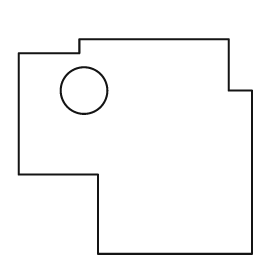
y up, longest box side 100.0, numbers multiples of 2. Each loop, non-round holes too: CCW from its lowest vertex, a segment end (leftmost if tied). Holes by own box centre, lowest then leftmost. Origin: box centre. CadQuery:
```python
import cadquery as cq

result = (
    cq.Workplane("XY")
    .moveTo(-16.0, -46.0)
    .lineTo(50.0, -46.0)
    .lineTo(50.0, 24.0)
    .lineTo(40.0, 24.0)
    .lineTo(40.0, 46.0)
    .lineTo(-24.0, 46.0)
    .lineTo(-24.0, 40.0)
    .lineTo(-50.0, 40.0)
    .lineTo(-50.0, -12.0)
    .lineTo(-16.0, -12.0)
    .close()
    .moveTo(-22.0, 24.0)
    .circle(10.0)
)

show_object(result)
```